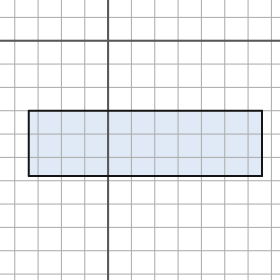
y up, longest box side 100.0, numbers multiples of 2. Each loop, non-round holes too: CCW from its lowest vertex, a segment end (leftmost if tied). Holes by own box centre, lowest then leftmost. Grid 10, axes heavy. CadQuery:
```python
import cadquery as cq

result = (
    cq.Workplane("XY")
    .moveTo(-34.0, -58.0)
    .lineTo(66.0, -58.0)
    .lineTo(66.0, -30.0)
    .lineTo(-34.0, -30.0)
    .close()
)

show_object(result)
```